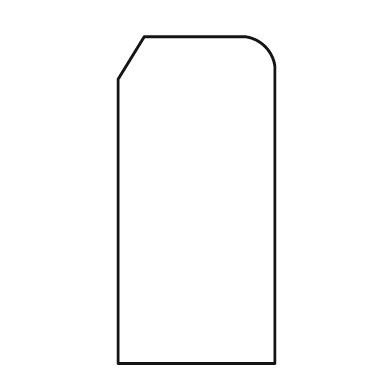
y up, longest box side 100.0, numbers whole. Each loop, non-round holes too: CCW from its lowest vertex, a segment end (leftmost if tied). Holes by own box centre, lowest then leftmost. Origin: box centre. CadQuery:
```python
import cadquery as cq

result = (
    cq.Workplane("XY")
    .moveTo(-24.0, -50.0)
    .lineTo(24.0, -50.0)
    .lineTo(24.0, 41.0)
    .threePointArc((21.0, 47.0), (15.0, 50.0))
    .lineTo(-16.0, 50.0)
    .lineTo(-24.0, 37.0)
    .close()
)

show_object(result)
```